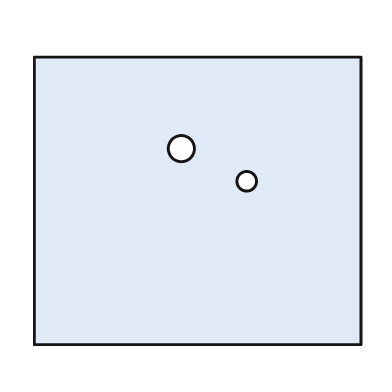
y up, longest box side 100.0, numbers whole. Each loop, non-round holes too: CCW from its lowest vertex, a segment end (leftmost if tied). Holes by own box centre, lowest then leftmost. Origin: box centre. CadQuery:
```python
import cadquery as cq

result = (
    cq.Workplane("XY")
    .moveTo(-50.0, -44.0)
    .lineTo(50.0, -44.0)
    .lineTo(50.0, 44.0)
    .lineTo(-50.0, 44.0)
    .close()
    .moveTo(15.0, 6.0)
    .circle(3.0)
    .moveTo(-5.0, 16.0)
    .circle(4.0)
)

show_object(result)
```